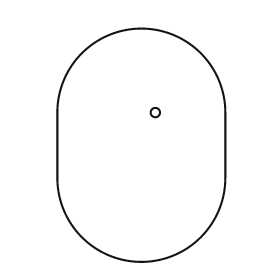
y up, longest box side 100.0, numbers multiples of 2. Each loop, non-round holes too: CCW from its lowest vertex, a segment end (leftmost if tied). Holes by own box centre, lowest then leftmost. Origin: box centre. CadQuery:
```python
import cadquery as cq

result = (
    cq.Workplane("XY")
    .moveTo(-36.0, -14.0)
    .threePointArc((0.0, -50.0), (36.0, -14.0))
    .lineTo(36.0, 14.0)
    .threePointArc((0.0, 50.0), (-36.0, 14.0))
    .close()
    .moveTo(6.0, 14.0)
    .circle(2.0)
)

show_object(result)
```